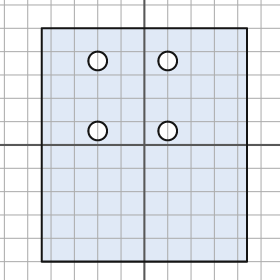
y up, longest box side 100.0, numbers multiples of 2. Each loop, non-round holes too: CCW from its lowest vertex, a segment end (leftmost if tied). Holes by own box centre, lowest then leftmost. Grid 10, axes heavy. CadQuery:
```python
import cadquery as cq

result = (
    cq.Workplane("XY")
    .moveTo(-44.0, -50.0)
    .lineTo(44.0, -50.0)
    .lineTo(44.0, 50.0)
    .lineTo(-44.0, 50.0)
    .close()
    .moveTo(-20.0, 6.0)
    .circle(4.0)
    .moveTo(10.0, 6.0)
    .circle(4.0)
    .moveTo(-20.0, 36.0)
    .circle(4.0)
    .moveTo(10.0, 36.0)
    .circle(4.0)
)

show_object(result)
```